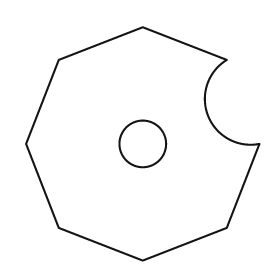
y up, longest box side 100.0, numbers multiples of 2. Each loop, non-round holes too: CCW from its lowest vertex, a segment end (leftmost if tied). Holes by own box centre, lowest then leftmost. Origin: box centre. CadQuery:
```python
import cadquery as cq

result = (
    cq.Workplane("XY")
    .moveTo(0.0, -50.0)
    .lineTo(36.0, -36.0)
    .lineTo(50.0, 0.0)
    .threePointArc((28.0, 12.0), (36.0, 36.0))
    .lineTo(0.0, 50.0)
    .lineTo(-36.0, 36.0)
    .lineTo(-50.0, 0.0)
    .lineTo(-36.0, -36.0)
    .close()
    .moveTo(0.0, 0.0)
    .circle(10.0)
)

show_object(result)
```